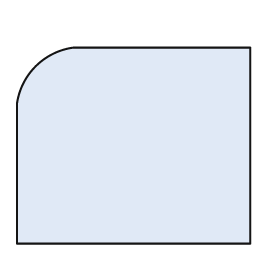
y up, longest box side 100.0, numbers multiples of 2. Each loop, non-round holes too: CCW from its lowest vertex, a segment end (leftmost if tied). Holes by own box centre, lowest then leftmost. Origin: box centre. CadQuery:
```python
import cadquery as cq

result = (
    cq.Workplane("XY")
    .moveTo(-50.0, -42.0)
    .lineTo(50.0, -42.0)
    .lineTo(50.0, 42.0)
    .lineTo(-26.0, 42.0)
    .threePointArc((-42.0, 34.0), (-50.0, 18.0))
    .close()
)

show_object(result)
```